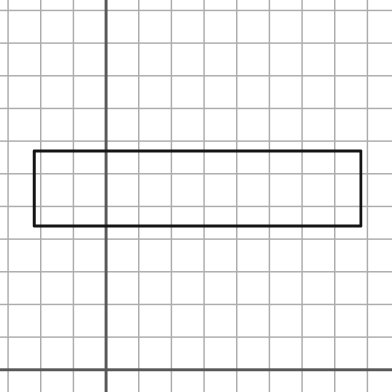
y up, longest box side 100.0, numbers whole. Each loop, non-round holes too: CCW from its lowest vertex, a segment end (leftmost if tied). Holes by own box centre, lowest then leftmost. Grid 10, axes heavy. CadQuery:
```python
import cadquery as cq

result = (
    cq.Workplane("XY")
    .moveTo(-22.0, 44.0)
    .lineTo(78.0, 44.0)
    .lineTo(78.0, 67.0)
    .lineTo(-22.0, 67.0)
    .close()
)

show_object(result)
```